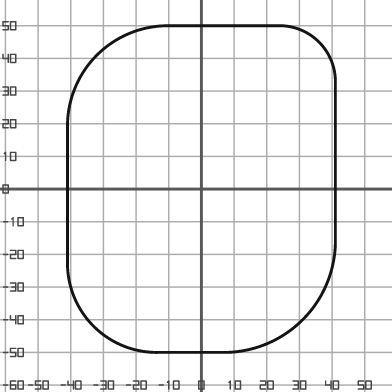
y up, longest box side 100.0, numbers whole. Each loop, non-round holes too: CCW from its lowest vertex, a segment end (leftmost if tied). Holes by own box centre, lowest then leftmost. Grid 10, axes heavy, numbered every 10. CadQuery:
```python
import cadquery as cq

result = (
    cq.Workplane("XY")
    .moveTo(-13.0, -50.0)
    .lineTo(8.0, -50.0)
    .threePointArc((31.0, -40.0), (41.0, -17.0))
    .lineTo(41.0, 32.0)
    .threePointArc((36.0, 45.0), (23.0, 50.0))
    .lineTo(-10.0, 50.0)
    .threePointArc((-32.0, 41.0), (-41.0, 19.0))
    .lineTo(-41.0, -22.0)
    .threePointArc((-33.0, -42.0), (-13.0, -50.0))
    .close()
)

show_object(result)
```